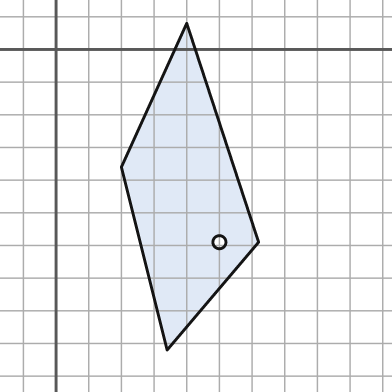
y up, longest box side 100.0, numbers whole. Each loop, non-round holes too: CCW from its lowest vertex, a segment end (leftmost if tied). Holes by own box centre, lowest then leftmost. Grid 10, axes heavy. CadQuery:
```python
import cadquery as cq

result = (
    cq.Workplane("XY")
    .moveTo(34.0, -92.0)
    .lineTo(62.0, -59.0)
    .lineTo(40.0, 8.0)
    .lineTo(20.0, -36.0)
    .close()
    .moveTo(50.0, -59.0)
    .circle(2.0)
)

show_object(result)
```